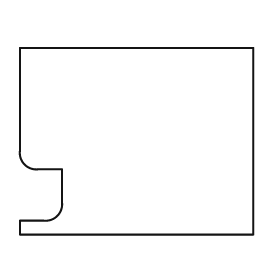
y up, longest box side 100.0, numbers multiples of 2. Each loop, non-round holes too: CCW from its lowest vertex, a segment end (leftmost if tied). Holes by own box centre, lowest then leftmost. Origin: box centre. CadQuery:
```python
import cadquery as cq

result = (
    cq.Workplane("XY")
    .moveTo(-50.0, -40.0)
    .lineTo(50.0, -40.0)
    .lineTo(50.0, 40.0)
    .lineTo(-50.0, 40.0)
    .lineTo(-50.0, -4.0)
    .threePointArc((-48.0, -10.0), (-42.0, -12.0))
    .lineTo(-32.0, -12.0)
    .lineTo(-32.0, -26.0)
    .threePointArc((-34.0, -32.0), (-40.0, -34.0))
    .lineTo(-50.0, -34.0)
    .close()
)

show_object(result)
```